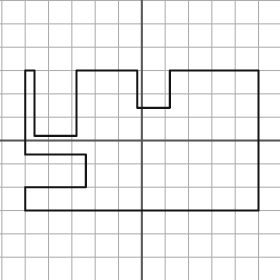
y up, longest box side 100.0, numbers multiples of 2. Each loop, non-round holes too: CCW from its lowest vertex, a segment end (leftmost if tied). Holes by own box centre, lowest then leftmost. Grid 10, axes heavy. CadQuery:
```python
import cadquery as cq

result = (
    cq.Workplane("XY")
    .moveTo(-50.0, -30.0)
    .lineTo(50.0, -30.0)
    .lineTo(50.0, 30.0)
    .lineTo(12.0, 30.0)
    .lineTo(12.0, 14.0)
    .lineTo(-2.0, 14.0)
    .lineTo(-2.0, 30.0)
    .lineTo(-28.0, 30.0)
    .lineTo(-28.0, 2.0)
    .lineTo(-46.0, 2.0)
    .lineTo(-46.0, 30.0)
    .lineTo(-50.0, 30.0)
    .lineTo(-50.0, -6.0)
    .lineTo(-24.0, -6.0)
    .lineTo(-24.0, -20.0)
    .lineTo(-50.0, -20.0)
    .close()
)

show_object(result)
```